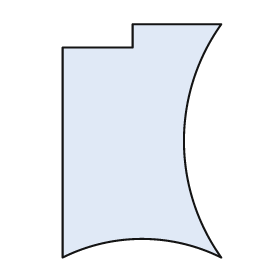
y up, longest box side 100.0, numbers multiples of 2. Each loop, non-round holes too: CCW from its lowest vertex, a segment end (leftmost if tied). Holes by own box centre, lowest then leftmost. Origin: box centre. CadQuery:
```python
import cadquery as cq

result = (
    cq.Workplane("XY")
    .moveTo(-34.0, -50.0)
    .threePointArc((0.0, -42.0), (34.0, -50.0))
    .threePointArc((18.0, 0.0), (34.0, 50.0))
    .lineTo(-4.0, 50.0)
    .lineTo(-4.0, 40.0)
    .lineTo(-34.0, 40.0)
    .close()
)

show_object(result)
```